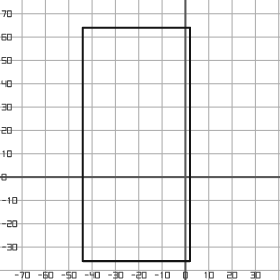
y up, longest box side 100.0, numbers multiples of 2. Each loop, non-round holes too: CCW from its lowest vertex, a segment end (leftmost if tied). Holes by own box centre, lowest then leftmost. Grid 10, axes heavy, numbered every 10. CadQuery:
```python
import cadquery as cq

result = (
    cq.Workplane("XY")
    .moveTo(-44.0, -36.0)
    .lineTo(2.0, -36.0)
    .lineTo(2.0, 64.0)
    .lineTo(-44.0, 64.0)
    .close()
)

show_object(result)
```